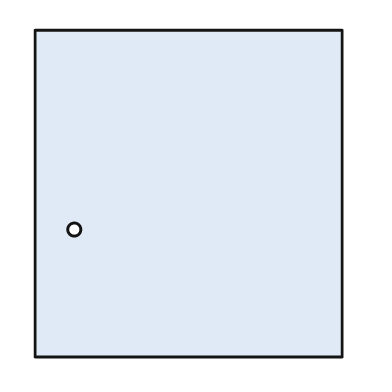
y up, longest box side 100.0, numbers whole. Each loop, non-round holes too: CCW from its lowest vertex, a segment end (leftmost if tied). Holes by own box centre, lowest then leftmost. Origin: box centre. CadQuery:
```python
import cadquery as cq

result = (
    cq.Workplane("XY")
    .moveTo(-47.0, -50.0)
    .lineTo(47.0, -50.0)
    .lineTo(47.0, 50.0)
    .lineTo(-47.0, 50.0)
    .close()
    .moveTo(-35.0, -11.0)
    .circle(2.0)
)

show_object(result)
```